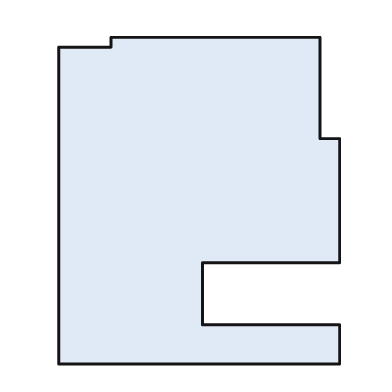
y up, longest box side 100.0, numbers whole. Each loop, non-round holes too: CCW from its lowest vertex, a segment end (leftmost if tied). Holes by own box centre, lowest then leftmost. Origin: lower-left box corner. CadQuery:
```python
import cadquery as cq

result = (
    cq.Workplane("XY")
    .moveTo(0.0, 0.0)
    .lineTo(86.0, 0.0)
    .lineTo(86.0, 12.0)
    .lineTo(44.0, 12.0)
    .lineTo(44.0, 31.0)
    .lineTo(86.0, 31.0)
    .lineTo(86.0, 69.0)
    .lineTo(80.0, 69.0)
    .lineTo(80.0, 100.0)
    .lineTo(16.0, 100.0)
    .lineTo(16.0, 97.0)
    .lineTo(0.0, 97.0)
    .close()
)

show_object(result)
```